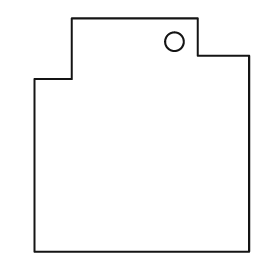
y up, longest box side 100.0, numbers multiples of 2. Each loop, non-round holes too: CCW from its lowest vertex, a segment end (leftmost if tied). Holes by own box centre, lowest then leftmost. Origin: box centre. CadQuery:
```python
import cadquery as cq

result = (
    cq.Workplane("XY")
    .moveTo(-46.0, -50.0)
    .lineTo(46.0, -50.0)
    .lineTo(46.0, 34.0)
    .lineTo(24.0, 34.0)
    .lineTo(24.0, 50.0)
    .lineTo(-30.0, 50.0)
    .lineTo(-30.0, 24.0)
    .lineTo(-46.0, 24.0)
    .close()
    .moveTo(14.0, 40.0)
    .circle(4.0)
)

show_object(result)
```